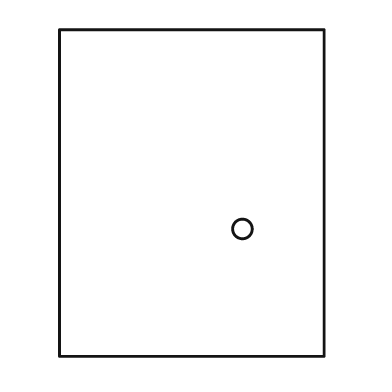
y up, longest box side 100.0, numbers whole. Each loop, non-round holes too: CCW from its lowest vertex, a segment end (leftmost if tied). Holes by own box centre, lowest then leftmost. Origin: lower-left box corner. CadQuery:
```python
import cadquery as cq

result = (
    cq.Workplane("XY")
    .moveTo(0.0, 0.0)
    .lineTo(81.0, 0.0)
    .lineTo(81.0, 100.0)
    .lineTo(0.0, 100.0)
    .close()
    .moveTo(56.0, 39.0)
    .circle(3.0)
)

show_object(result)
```